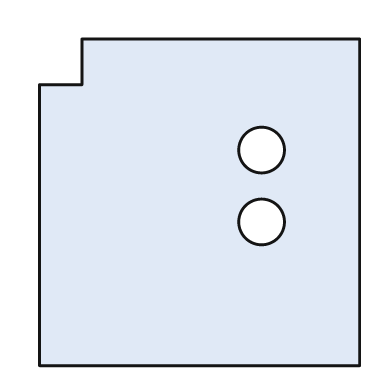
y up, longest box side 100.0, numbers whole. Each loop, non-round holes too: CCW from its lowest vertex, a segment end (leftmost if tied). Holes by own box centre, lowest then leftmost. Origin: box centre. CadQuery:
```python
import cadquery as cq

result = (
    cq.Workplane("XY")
    .moveTo(-49.0, -50.0)
    .lineTo(49.0, -50.0)
    .lineTo(49.0, 50.0)
    .lineTo(-36.0, 50.0)
    .lineTo(-36.0, 36.0)
    .lineTo(-49.0, 36.0)
    .close()
    .moveTo(19.0, -6.0)
    .circle(7.0)
    .moveTo(19.0, 16.0)
    .circle(7.0)
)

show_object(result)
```